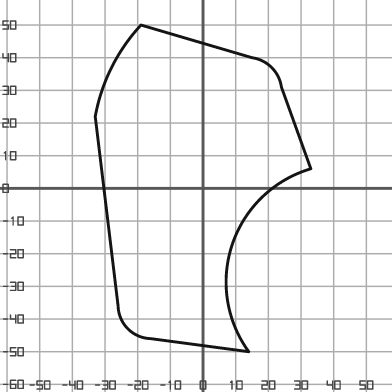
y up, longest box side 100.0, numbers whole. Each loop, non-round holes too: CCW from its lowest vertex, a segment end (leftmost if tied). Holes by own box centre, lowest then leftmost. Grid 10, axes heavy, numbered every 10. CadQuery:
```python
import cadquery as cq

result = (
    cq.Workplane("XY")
    .moveTo(14.0, -50.0)
    .threePointArc((9.0, -17.0), (33.0, 6.0))
    .lineTo(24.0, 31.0)
    .threePointArc((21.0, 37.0), (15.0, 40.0))
    .lineTo(-19.0, 50.0)
    .threePointArc((-28.0, 37.0), (-33.0, 22.0))
    .lineTo(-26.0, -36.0)
    .threePointArc((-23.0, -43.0), (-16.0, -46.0))
    .close()
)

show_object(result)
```